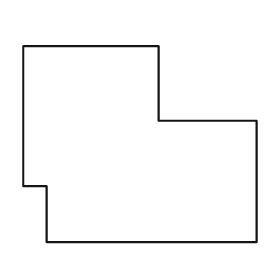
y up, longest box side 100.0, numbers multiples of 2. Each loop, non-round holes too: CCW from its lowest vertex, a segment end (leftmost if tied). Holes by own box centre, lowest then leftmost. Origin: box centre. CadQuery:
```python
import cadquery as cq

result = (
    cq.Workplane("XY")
    .moveTo(-40.0, -42.0)
    .lineTo(50.0, -42.0)
    .lineTo(50.0, 10.0)
    .lineTo(8.0, 10.0)
    .lineTo(8.0, 42.0)
    .lineTo(-50.0, 42.0)
    .lineTo(-50.0, -18.0)
    .lineTo(-40.0, -18.0)
    .close()
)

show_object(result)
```